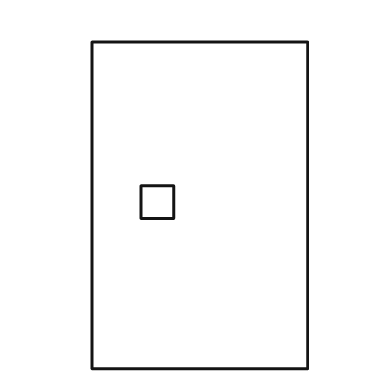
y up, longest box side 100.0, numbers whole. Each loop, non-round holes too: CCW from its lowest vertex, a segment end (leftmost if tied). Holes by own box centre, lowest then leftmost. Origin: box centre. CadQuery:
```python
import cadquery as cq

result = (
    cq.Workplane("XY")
    .moveTo(-33.0, -50.0)
    .lineTo(33.0, -50.0)
    .lineTo(33.0, 50.0)
    .lineTo(-33.0, 50.0)
    .close()
    .moveTo(-18.0, -4.0)
    .lineTo(-8.0, -4.0)
    .lineTo(-8.0, 6.0)
    .lineTo(-18.0, 6.0)
    .close()
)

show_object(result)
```